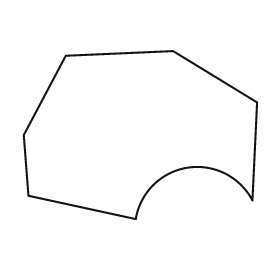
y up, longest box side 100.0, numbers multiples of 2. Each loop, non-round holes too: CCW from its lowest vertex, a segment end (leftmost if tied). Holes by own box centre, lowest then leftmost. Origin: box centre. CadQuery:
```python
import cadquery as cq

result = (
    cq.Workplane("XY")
    .moveTo(-2.0, -36.0)
    .threePointArc((20.0, -14.0), (48.0, -28.0))
    .lineTo(50.0, 14.0)
    .lineTo(14.0, 36.0)
    .lineTo(-32.0, 34.0)
    .lineTo(-50.0, 0.0)
    .lineTo(-48.0, -26.0)
    .close()
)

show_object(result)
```